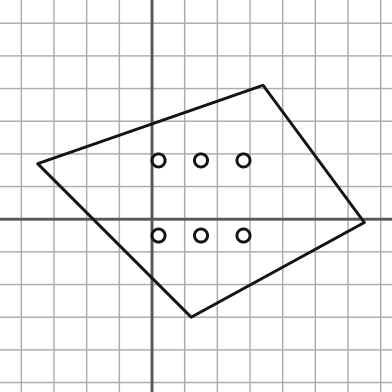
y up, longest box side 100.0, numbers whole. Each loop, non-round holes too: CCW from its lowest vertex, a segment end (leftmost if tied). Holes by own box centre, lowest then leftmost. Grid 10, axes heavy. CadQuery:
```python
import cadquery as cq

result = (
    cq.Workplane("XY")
    .moveTo(12.0, -30.0)
    .lineTo(65.0, -1.0)
    .lineTo(34.0, 41.0)
    .lineTo(-35.0, 17.0)
    .close()
    .moveTo(2.0, -5.0)
    .circle(2.0)
    .moveTo(15.0, -5.0)
    .circle(2.0)
    .moveTo(28.0, -5.0)
    .circle(2.0)
    .moveTo(2.0, 18.0)
    .circle(2.0)
    .moveTo(15.0, 18.0)
    .circle(2.0)
    .moveTo(28.0, 18.0)
    .circle(2.0)
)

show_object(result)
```